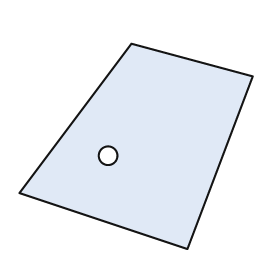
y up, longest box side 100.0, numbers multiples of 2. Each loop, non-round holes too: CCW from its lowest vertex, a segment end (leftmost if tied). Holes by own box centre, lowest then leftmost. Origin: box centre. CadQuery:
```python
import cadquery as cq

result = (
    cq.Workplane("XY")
    .moveTo(22.0, -44.0)
    .lineTo(50.0, 30.0)
    .lineTo(-2.0, 44.0)
    .lineTo(-50.0, -20.0)
    .close()
    .moveTo(-12.0, -4.0)
    .circle(4.0)
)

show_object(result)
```